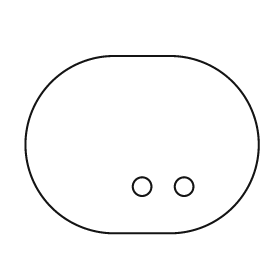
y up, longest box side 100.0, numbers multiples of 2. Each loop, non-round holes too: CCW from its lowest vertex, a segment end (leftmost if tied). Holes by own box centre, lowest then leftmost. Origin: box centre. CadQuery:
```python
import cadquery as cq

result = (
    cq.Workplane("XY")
    .moveTo(-12.0, -38.0)
    .lineTo(12.0, -38.0)
    .threePointArc((50.0, 0.0), (12.0, 38.0))
    .lineTo(-12.0, 38.0)
    .threePointArc((-50.0, 0.0), (-12.0, -38.0))
    .close()
    .moveTo(0.0, -18.0)
    .circle(4.0)
    .moveTo(18.0, -18.0)
    .circle(4.0)
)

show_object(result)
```